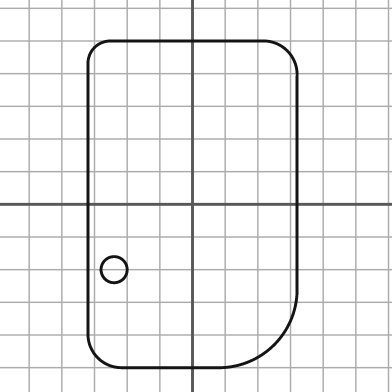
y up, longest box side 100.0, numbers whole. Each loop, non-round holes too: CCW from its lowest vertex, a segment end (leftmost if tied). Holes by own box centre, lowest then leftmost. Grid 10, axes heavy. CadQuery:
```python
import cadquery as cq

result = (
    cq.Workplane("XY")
    .moveTo(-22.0, -50.0)
    .lineTo(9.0, -50.0)
    .threePointArc((25.0, -43.0), (32.0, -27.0))
    .lineTo(32.0, 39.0)
    .threePointArc((29.0, 47.0), (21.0, 50.0))
    .lineTo(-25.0, 50.0)
    .threePointArc((-30.0, 48.0), (-32.0, 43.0))
    .lineTo(-32.0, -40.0)
    .threePointArc((-29.0, -47.0), (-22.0, -50.0))
    .close()
    .moveTo(-24.0, -20.0)
    .circle(4.0)
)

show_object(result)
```